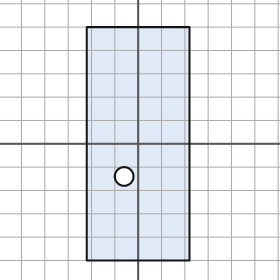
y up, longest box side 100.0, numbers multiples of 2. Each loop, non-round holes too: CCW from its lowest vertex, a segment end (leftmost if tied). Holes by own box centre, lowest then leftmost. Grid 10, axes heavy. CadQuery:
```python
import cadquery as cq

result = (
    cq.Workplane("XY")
    .moveTo(-22.0, -50.0)
    .lineTo(22.0, -50.0)
    .lineTo(22.0, 50.0)
    .lineTo(-22.0, 50.0)
    .close()
    .moveTo(-6.0, -14.0)
    .circle(4.0)
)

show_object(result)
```